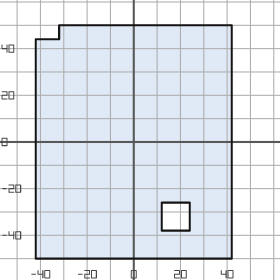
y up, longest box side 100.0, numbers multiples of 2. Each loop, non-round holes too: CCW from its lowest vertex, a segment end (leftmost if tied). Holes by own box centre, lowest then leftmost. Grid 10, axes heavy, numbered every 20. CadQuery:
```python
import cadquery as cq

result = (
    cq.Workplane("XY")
    .moveTo(-42.0, -50.0)
    .lineTo(42.0, -50.0)
    .lineTo(42.0, 50.0)
    .lineTo(-32.0, 50.0)
    .lineTo(-32.0, 44.0)
    .lineTo(-42.0, 44.0)
    .close()
    .moveTo(12.0, -38.0)
    .lineTo(24.0, -38.0)
    .lineTo(24.0, -26.0)
    .lineTo(12.0, -26.0)
    .close()
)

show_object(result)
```